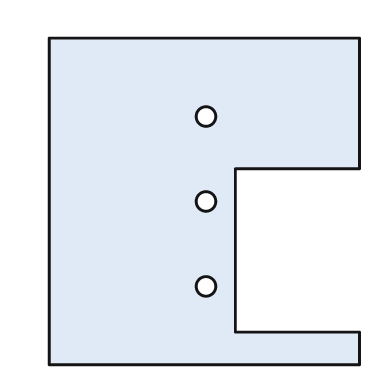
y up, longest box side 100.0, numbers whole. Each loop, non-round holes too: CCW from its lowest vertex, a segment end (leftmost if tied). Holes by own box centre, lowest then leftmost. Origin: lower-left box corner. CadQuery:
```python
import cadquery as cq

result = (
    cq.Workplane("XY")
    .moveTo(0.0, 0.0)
    .lineTo(95.0, 0.0)
    .lineTo(95.0, 10.0)
    .lineTo(57.0, 10.0)
    .lineTo(57.0, 60.0)
    .lineTo(95.0, 60.0)
    .lineTo(95.0, 100.0)
    .lineTo(0.0, 100.0)
    .close()
    .moveTo(48.0, 24.0)
    .circle(3.0)
    .moveTo(48.0, 50.0)
    .circle(3.0)
    .moveTo(48.0, 76.0)
    .circle(3.0)
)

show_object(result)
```